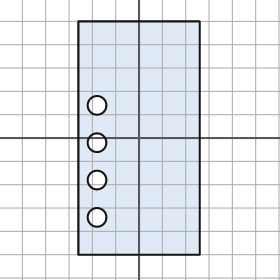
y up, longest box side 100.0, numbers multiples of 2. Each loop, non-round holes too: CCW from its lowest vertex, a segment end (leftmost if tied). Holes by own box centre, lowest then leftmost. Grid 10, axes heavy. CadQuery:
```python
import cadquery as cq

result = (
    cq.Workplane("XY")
    .moveTo(-26.0, -50.0)
    .lineTo(26.0, -50.0)
    .lineTo(26.0, 50.0)
    .lineTo(-26.0, 50.0)
    .close()
    .moveTo(-18.0, -34.0)
    .circle(4.0)
    .moveTo(-18.0, -18.0)
    .circle(4.0)
    .moveTo(-18.0, -2.0)
    .circle(4.0)
    .moveTo(-18.0, 14.0)
    .circle(4.0)
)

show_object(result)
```